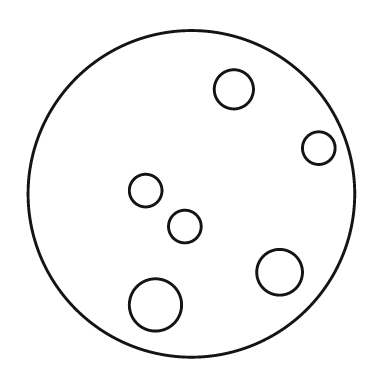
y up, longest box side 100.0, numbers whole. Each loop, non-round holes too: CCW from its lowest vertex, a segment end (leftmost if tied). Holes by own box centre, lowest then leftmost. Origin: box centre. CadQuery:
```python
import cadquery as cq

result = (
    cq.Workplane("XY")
    .moveTo(0.0, 0.0)
    .circle(50.0)
    .moveTo(-11.0, -34.0)
    .circle(8.0)
    .moveTo(27.0, -24.0)
    .circle(7.0)
    .moveTo(-2.0, -10.0)
    .circle(5.0)
    .moveTo(-14.0, 1.0)
    .circle(5.0)
    .moveTo(39.0, 14.0)
    .circle(5.0)
    .moveTo(13.0, 32.0)
    .circle(6.0)
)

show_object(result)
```